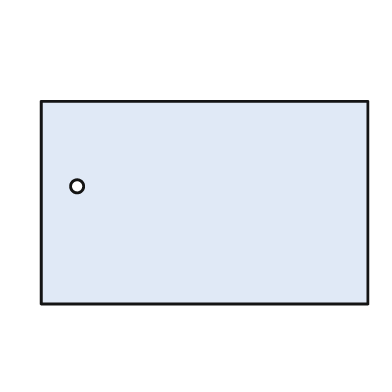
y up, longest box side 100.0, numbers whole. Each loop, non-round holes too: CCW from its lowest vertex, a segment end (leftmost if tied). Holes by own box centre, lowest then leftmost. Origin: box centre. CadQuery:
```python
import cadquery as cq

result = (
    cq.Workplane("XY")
    .moveTo(-50.0, -31.0)
    .lineTo(50.0, -31.0)
    .lineTo(50.0, 31.0)
    .lineTo(-50.0, 31.0)
    .close()
    .moveTo(-39.0, 5.0)
    .circle(2.0)
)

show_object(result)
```